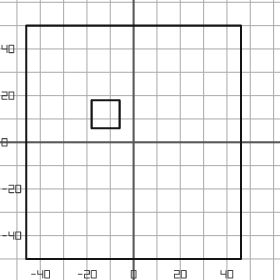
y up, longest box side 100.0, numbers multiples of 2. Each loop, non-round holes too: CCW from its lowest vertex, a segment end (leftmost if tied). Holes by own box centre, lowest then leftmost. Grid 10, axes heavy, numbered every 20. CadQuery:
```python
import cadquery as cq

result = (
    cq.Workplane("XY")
    .moveTo(-46.0, -50.0)
    .lineTo(46.0, -50.0)
    .lineTo(46.0, 50.0)
    .lineTo(-46.0, 50.0)
    .close()
    .moveTo(-18.0, 6.0)
    .lineTo(-6.0, 6.0)
    .lineTo(-6.0, 18.0)
    .lineTo(-18.0, 18.0)
    .close()
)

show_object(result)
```